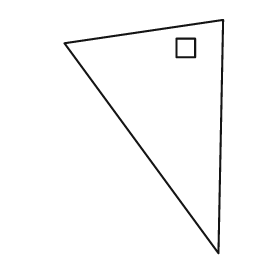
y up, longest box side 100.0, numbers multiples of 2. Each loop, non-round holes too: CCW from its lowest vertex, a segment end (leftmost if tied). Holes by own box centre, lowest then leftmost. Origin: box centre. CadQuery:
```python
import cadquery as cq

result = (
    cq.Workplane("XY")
    .moveTo(32.0, -50.0)
    .lineTo(34.0, 50.0)
    .lineTo(-34.0, 40.0)
    .close()
    .moveTo(14.0, 34.0)
    .lineTo(22.0, 34.0)
    .lineTo(22.0, 42.0)
    .lineTo(14.0, 42.0)
    .close()
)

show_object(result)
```